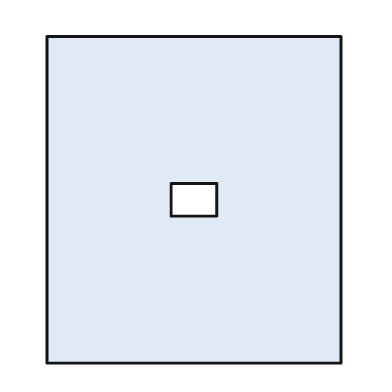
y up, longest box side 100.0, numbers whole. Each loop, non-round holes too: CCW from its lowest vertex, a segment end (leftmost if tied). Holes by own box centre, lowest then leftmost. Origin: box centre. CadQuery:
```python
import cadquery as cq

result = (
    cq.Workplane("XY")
    .moveTo(-45.0, -50.0)
    .lineTo(45.0, -50.0)
    .lineTo(45.0, 50.0)
    .lineTo(-45.0, 50.0)
    .close()
    .moveTo(-7.0, -5.0)
    .lineTo(7.0, -5.0)
    .lineTo(7.0, 5.0)
    .lineTo(-7.0, 5.0)
    .close()
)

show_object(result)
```